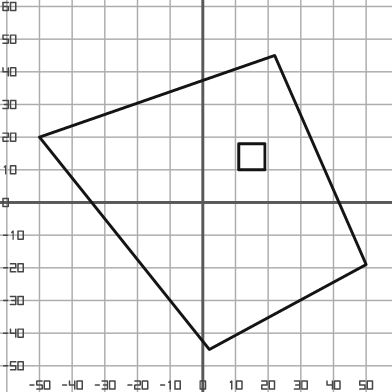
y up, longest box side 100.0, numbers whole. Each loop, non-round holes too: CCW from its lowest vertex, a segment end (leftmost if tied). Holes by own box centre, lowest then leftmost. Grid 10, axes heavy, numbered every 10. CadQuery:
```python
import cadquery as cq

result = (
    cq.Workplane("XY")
    .moveTo(2.0, -45.0)
    .lineTo(50.0, -19.0)
    .lineTo(22.0, 45.0)
    .lineTo(-50.0, 20.0)
    .close()
    .moveTo(11.0, 10.0)
    .lineTo(19.0, 10.0)
    .lineTo(19.0, 18.0)
    .lineTo(11.0, 18.0)
    .close()
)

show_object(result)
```